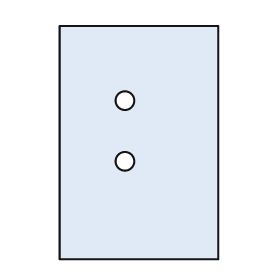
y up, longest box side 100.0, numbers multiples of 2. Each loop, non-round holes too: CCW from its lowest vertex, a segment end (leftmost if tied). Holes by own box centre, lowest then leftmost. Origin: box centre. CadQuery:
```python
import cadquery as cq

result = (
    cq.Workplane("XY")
    .moveTo(-34.0, -50.0)
    .lineTo(34.0, -50.0)
    .lineTo(34.0, 50.0)
    .lineTo(-34.0, 50.0)
    .close()
    .moveTo(-6.0, -8.0)
    .circle(4.0)
    .moveTo(-6.0, 18.0)
    .circle(4.0)
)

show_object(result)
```